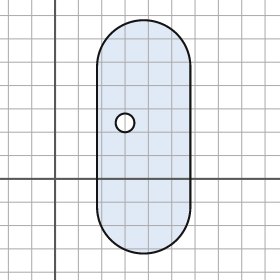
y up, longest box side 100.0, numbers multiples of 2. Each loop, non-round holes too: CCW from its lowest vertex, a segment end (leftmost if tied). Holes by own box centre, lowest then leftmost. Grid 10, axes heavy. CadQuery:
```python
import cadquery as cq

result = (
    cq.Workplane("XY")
    .moveTo(18.0, -12.0)
    .threePointArc((38.0, -32.0), (58.0, -12.0))
    .lineTo(58.0, 48.0)
    .threePointArc((38.0, 68.0), (18.0, 48.0))
    .close()
    .moveTo(30.0, 24.0)
    .circle(4.0)
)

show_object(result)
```